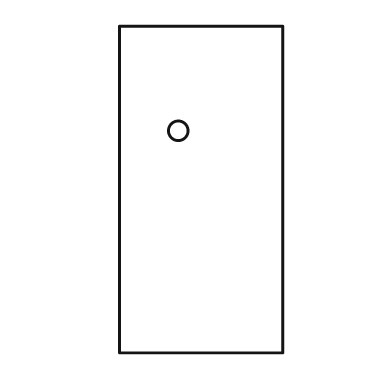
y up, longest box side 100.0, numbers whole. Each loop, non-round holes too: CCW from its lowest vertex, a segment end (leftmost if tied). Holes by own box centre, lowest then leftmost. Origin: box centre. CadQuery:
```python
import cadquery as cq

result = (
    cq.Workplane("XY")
    .moveTo(-25.0, -50.0)
    .lineTo(25.0, -50.0)
    .lineTo(25.0, 50.0)
    .lineTo(-25.0, 50.0)
    .close()
    .moveTo(-7.0, 18.0)
    .circle(3.0)
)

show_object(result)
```